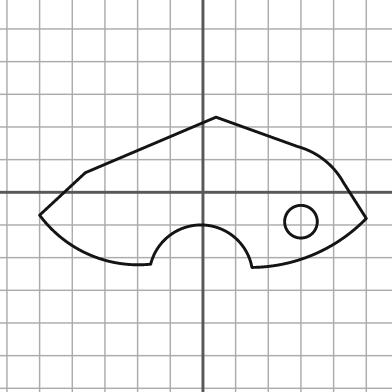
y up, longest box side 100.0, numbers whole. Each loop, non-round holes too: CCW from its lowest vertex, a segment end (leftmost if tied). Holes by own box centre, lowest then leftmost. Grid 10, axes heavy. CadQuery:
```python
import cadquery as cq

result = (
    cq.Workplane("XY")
    .moveTo(15.0, -23.0)
    .threePointArc((34.0, -19.0), (50.0, -8.0))
    .lineTo(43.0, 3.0)
    .threePointArc((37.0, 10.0), (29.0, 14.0))
    .lineTo(4.0, 23.0)
    .lineTo(-36.0, 6.0)
    .lineTo(-50.0, -7.0)
    .threePointArc((-35.0, -19.0), (-16.0, -22.0))
    .threePointArc((0.0, -10.0), (15.0, -23.0))
    .close()
    .moveTo(30.0, -9.0)
    .circle(5.0)
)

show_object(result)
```